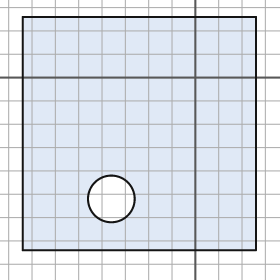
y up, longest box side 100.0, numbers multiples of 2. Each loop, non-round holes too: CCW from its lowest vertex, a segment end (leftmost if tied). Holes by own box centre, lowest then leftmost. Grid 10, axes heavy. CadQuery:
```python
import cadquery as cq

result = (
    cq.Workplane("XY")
    .moveTo(-74.0, -74.0)
    .lineTo(26.0, -74.0)
    .lineTo(26.0, 26.0)
    .lineTo(-74.0, 26.0)
    .close()
    .moveTo(-36.0, -52.0)
    .circle(10.0)
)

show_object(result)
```